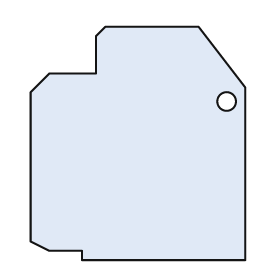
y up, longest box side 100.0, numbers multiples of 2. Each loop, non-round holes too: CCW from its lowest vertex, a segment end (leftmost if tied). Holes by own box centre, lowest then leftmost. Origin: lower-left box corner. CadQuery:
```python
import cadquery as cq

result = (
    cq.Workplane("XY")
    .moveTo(22.0, 0.0)
    .lineTo(92.0, 0.0)
    .lineTo(92.0, 74.0)
    .lineTo(72.0, 100.0)
    .lineTo(32.0, 100.0)
    .lineTo(28.0, 96.0)
    .lineTo(28.0, 80.0)
    .lineTo(8.0, 80.0)
    .lineTo(0.0, 72.0)
    .lineTo(0.0, 8.0)
    .lineTo(8.0, 4.0)
    .lineTo(22.0, 4.0)
    .close()
    .moveTo(84.0, 68.0)
    .circle(4.0)
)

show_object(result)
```